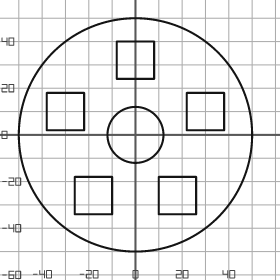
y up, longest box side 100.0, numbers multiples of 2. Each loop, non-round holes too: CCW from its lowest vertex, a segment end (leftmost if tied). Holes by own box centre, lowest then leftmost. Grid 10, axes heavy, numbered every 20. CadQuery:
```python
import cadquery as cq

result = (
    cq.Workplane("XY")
    .moveTo(0.0, 0.0)
    .circle(50.0)
    .moveTo(-26.0, -34.0)
    .lineTo(-10.0, -34.0)
    .lineTo(-10.0, -18.0)
    .lineTo(-26.0, -18.0)
    .close()
    .moveTo(10.0, -34.0)
    .lineTo(26.0, -34.0)
    .lineTo(26.0, -18.0)
    .lineTo(10.0, -18.0)
    .close()
    .moveTo(0.0, 0.0)
    .circle(12.0)
    .moveTo(-38.0, 2.0)
    .lineTo(-22.0, 2.0)
    .lineTo(-22.0, 18.0)
    .lineTo(-38.0, 18.0)
    .close()
    .moveTo(22.0, 2.0)
    .lineTo(38.0, 2.0)
    .lineTo(38.0, 18.0)
    .lineTo(22.0, 18.0)
    .close()
    .moveTo(-8.0, 24.0)
    .lineTo(8.0, 24.0)
    .lineTo(8.0, 40.0)
    .lineTo(-8.0, 40.0)
    .close()
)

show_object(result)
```